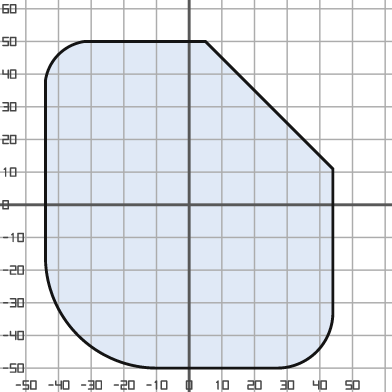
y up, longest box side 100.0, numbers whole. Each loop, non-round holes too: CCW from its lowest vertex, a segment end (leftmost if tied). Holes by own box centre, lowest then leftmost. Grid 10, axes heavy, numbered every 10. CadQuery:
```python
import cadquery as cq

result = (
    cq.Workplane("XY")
    .moveTo(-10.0, -50.0)
    .lineTo(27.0, -50.0)
    .threePointArc((39.0, -45.0), (44.0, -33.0))
    .lineTo(44.0, 11.0)
    .lineTo(5.0, 50.0)
    .lineTo(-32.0, 50.0)
    .threePointArc((-40.0, 46.0), (-44.0, 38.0))
    .lineTo(-44.0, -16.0)
    .threePointArc((-34.0, -40.0), (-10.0, -50.0))
    .close()
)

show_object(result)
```